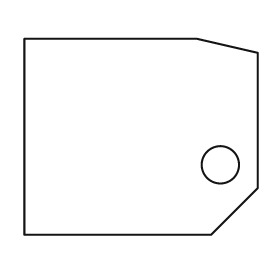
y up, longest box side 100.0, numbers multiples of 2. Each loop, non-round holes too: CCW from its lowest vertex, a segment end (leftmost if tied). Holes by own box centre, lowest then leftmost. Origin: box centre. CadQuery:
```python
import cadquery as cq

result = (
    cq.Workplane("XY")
    .moveTo(-50.0, -42.0)
    .lineTo(30.0, -42.0)
    .lineTo(50.0, -22.0)
    .lineTo(50.0, 36.0)
    .lineTo(24.0, 42.0)
    .lineTo(-50.0, 42.0)
    .close()
    .moveTo(34.0, -12.0)
    .circle(8.0)
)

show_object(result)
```